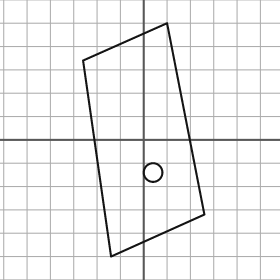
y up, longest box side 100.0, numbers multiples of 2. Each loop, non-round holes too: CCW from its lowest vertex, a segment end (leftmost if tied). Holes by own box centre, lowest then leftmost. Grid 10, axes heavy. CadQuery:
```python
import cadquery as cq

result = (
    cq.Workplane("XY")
    .moveTo(-14.0, -50.0)
    .lineTo(26.0, -32.0)
    .lineTo(10.0, 50.0)
    .lineTo(-26.0, 34.0)
    .close()
    .moveTo(4.0, -14.0)
    .circle(4.0)
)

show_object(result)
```